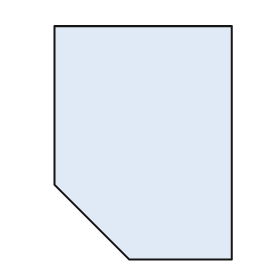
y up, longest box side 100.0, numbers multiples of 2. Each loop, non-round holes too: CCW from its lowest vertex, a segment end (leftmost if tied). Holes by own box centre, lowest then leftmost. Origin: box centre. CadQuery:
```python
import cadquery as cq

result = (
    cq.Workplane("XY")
    .moveTo(-6.0, -50.0)
    .lineTo(38.0, -50.0)
    .lineTo(38.0, 50.0)
    .lineTo(-38.0, 50.0)
    .lineTo(-38.0, -18.0)
    .close()
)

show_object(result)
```